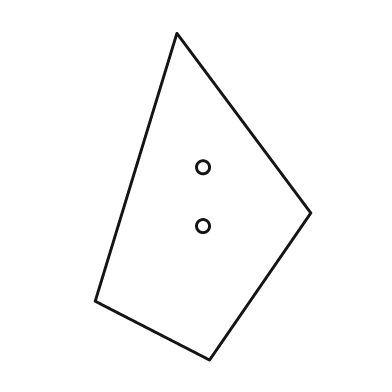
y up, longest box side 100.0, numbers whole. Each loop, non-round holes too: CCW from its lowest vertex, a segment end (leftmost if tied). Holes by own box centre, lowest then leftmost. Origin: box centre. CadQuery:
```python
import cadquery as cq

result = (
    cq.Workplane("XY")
    .moveTo(2.0, -50.0)
    .lineTo(33.0, -5.0)
    .lineTo(-8.0, 50.0)
    .lineTo(-33.0, -32.0)
    .close()
    .moveTo(0.0, -9.0)
    .circle(2.0)
    .moveTo(0.0, 9.0)
    .circle(2.0)
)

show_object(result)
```